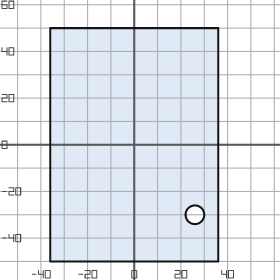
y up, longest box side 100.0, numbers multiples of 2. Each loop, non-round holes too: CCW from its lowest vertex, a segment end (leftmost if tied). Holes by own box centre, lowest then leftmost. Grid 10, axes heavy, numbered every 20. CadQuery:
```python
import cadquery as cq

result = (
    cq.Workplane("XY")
    .moveTo(-36.0, -50.0)
    .lineTo(36.0, -50.0)
    .lineTo(36.0, 50.0)
    .lineTo(-36.0, 50.0)
    .close()
    .moveTo(26.0, -30.0)
    .circle(4.0)
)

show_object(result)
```